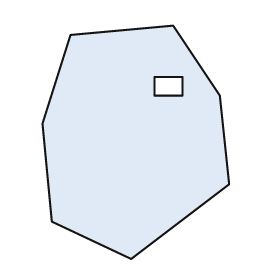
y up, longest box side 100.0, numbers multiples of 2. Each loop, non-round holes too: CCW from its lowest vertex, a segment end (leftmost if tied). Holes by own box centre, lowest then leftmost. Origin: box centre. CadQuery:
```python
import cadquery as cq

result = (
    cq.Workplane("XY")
    .moveTo(-2.0, -50.0)
    .lineTo(40.0, -18.0)
    .lineTo(36.0, 20.0)
    .lineTo(16.0, 50.0)
    .lineTo(-28.0, 46.0)
    .lineTo(-40.0, 8.0)
    .lineTo(-36.0, -34.0)
    .close()
    .moveTo(8.0, 20.0)
    .lineTo(20.0, 20.0)
    .lineTo(20.0, 28.0)
    .lineTo(8.0, 28.0)
    .close()
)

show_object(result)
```